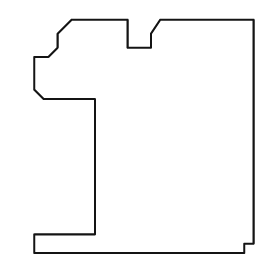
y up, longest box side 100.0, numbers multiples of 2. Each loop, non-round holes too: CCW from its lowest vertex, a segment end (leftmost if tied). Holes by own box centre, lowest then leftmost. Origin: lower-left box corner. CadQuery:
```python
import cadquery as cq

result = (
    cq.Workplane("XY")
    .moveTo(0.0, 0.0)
    .lineTo(90.0, 0.0)
    .lineTo(90.0, 4.0)
    .lineTo(94.0, 4.0)
    .lineTo(94.0, 100.0)
    .lineTo(54.0, 100.0)
    .lineTo(50.0, 94.0)
    .lineTo(50.0, 88.0)
    .lineTo(40.0, 88.0)
    .lineTo(40.0, 100.0)
    .lineTo(16.0, 100.0)
    .lineTo(10.0, 94.0)
    .lineTo(10.0, 88.0)
    .lineTo(6.0, 84.0)
    .lineTo(0.0, 84.0)
    .lineTo(0.0, 70.0)
    .lineTo(4.0, 66.0)
    .lineTo(26.0, 66.0)
    .lineTo(26.0, 8.0)
    .lineTo(0.0, 8.0)
    .close()
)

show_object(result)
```